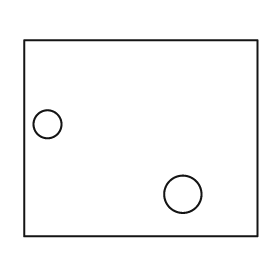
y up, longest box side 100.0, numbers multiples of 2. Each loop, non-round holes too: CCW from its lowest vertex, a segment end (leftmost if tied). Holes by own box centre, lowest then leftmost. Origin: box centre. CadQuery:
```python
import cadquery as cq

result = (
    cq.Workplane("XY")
    .moveTo(-50.0, -42.0)
    .lineTo(50.0, -42.0)
    .lineTo(50.0, 42.0)
    .lineTo(-50.0, 42.0)
    .close()
    .moveTo(18.0, -24.0)
    .circle(8.0)
    .moveTo(-40.0, 6.0)
    .circle(6.0)
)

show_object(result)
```